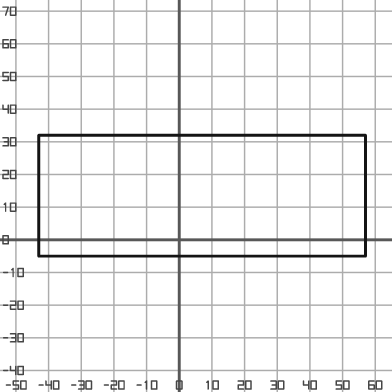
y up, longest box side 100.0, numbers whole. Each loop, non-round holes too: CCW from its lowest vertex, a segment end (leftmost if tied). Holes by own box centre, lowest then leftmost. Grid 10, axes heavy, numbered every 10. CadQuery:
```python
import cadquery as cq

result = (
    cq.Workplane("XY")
    .moveTo(-43.0, -5.0)
    .lineTo(57.0, -5.0)
    .lineTo(57.0, 32.0)
    .lineTo(-43.0, 32.0)
    .close()
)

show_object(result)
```